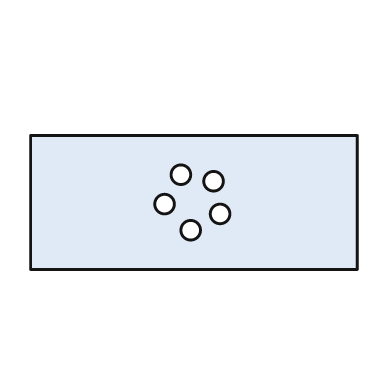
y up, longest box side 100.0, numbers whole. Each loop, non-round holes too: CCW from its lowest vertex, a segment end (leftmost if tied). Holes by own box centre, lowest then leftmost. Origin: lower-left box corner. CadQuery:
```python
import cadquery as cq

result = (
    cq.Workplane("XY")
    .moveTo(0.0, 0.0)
    .lineTo(100.0, 0.0)
    .lineTo(100.0, 41.0)
    .lineTo(0.0, 41.0)
    .close()
    .moveTo(49.0, 12.0)
    .circle(3.0)
    .moveTo(58.0, 17.0)
    .circle(3.0)
    .moveTo(41.0, 20.0)
    .circle(3.0)
    .moveTo(56.0, 27.0)
    .circle(3.0)
    .moveTo(46.0, 29.0)
    .circle(3.0)
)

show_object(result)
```